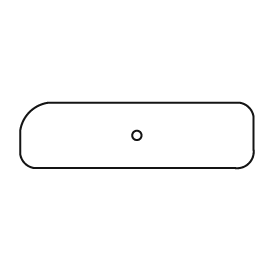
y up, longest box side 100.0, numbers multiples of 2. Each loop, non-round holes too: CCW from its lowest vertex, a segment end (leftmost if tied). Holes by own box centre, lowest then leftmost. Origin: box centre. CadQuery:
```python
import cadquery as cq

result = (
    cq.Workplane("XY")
    .moveTo(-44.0, -14.0)
    .lineTo(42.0, -14.0)
    .threePointArc((48.0, -12.0), (50.0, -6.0))
    .lineTo(50.0, 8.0)
    .threePointArc((48.0, 12.0), (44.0, 14.0))
    .lineTo(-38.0, 14.0)
    .threePointArc((-46.0, 10.0), (-50.0, 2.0))
    .lineTo(-50.0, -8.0)
    .threePointArc((-48.0, -12.0), (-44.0, -14.0))
    .close()
    .moveTo(0.0, 0.0)
    .circle(2.0)
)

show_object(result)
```